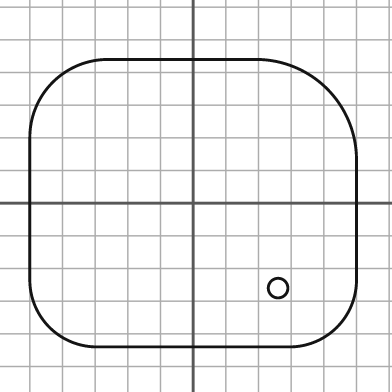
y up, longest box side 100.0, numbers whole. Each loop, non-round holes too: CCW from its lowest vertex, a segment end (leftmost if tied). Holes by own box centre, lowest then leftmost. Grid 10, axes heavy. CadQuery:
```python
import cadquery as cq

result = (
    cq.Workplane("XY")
    .moveTo(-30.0, -44.0)
    .lineTo(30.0, -44.0)
    .threePointArc((44.0, -38.0), (50.0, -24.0))
    .lineTo(50.0, 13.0)
    .threePointArc((41.0, 35.0), (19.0, 44.0))
    .lineTo(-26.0, 44.0)
    .threePointArc((-43.0, 37.0), (-50.0, 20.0))
    .lineTo(-50.0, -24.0)
    .threePointArc((-44.0, -38.0), (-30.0, -44.0))
    .close()
    .moveTo(26.0, -26.0)
    .circle(3.0)
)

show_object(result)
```